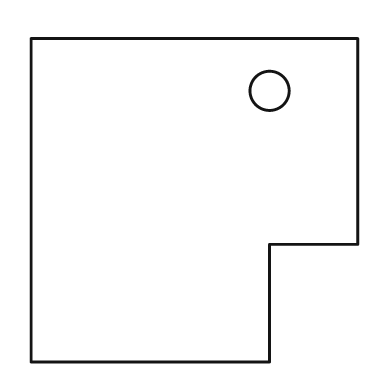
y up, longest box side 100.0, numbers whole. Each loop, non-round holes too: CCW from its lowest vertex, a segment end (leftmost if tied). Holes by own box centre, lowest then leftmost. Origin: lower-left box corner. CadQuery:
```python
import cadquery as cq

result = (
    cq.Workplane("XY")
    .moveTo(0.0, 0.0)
    .lineTo(73.0, 0.0)
    .lineTo(73.0, 36.0)
    .lineTo(100.0, 36.0)
    .lineTo(100.0, 99.0)
    .lineTo(0.0, 99.0)
    .close()
    .moveTo(73.0, 83.0)
    .circle(6.0)
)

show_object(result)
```